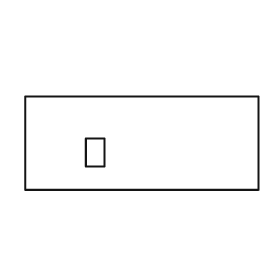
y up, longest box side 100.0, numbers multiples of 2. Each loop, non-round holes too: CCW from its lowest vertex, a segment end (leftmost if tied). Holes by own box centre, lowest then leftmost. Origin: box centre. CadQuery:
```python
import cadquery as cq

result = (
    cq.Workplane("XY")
    .moveTo(-50.0, -20.0)
    .lineTo(50.0, -20.0)
    .lineTo(50.0, 20.0)
    .lineTo(-50.0, 20.0)
    .close()
    .moveTo(-24.0, -10.0)
    .lineTo(-16.0, -10.0)
    .lineTo(-16.0, 2.0)
    .lineTo(-24.0, 2.0)
    .close()
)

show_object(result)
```